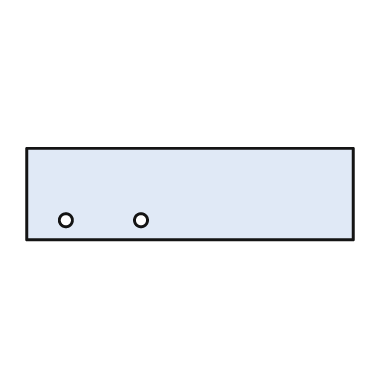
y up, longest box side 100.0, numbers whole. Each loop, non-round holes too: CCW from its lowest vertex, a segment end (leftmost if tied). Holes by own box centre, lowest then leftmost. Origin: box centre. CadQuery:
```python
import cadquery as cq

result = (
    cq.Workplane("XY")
    .moveTo(-50.0, -14.0)
    .lineTo(50.0, -14.0)
    .lineTo(50.0, 14.0)
    .lineTo(-50.0, 14.0)
    .close()
    .moveTo(-38.0, -8.0)
    .circle(2.0)
    .moveTo(-15.0, -8.0)
    .circle(2.0)
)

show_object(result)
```